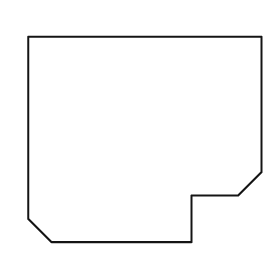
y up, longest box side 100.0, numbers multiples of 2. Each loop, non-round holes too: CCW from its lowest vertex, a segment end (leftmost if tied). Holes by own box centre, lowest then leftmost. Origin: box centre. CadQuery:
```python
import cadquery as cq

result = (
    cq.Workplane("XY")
    .moveTo(-40.0, -44.0)
    .lineTo(20.0, -44.0)
    .lineTo(20.0, -24.0)
    .lineTo(40.0, -24.0)
    .lineTo(50.0, -14.0)
    .lineTo(50.0, 44.0)
    .lineTo(-50.0, 44.0)
    .lineTo(-50.0, -34.0)
    .close()
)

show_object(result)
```